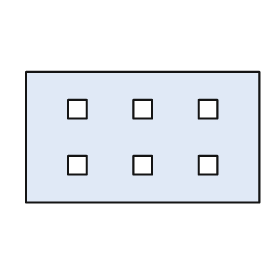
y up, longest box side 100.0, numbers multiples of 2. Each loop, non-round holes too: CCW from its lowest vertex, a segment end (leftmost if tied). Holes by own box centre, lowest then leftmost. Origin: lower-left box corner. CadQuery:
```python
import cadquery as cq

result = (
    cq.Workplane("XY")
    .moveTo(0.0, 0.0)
    .lineTo(100.0, 0.0)
    .lineTo(100.0, 56.0)
    .lineTo(0.0, 56.0)
    .close()
    .moveTo(18.0, 12.0)
    .lineTo(26.0, 12.0)
    .lineTo(26.0, 20.0)
    .lineTo(18.0, 20.0)
    .close()
    .moveTo(46.0, 12.0)
    .lineTo(54.0, 12.0)
    .lineTo(54.0, 20.0)
    .lineTo(46.0, 20.0)
    .close()
    .moveTo(74.0, 12.0)
    .lineTo(82.0, 12.0)
    .lineTo(82.0, 20.0)
    .lineTo(74.0, 20.0)
    .close()
    .moveTo(18.0, 36.0)
    .lineTo(26.0, 36.0)
    .lineTo(26.0, 44.0)
    .lineTo(18.0, 44.0)
    .close()
    .moveTo(46.0, 36.0)
    .lineTo(54.0, 36.0)
    .lineTo(54.0, 44.0)
    .lineTo(46.0, 44.0)
    .close()
    .moveTo(74.0, 36.0)
    .lineTo(82.0, 36.0)
    .lineTo(82.0, 44.0)
    .lineTo(74.0, 44.0)
    .close()
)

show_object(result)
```